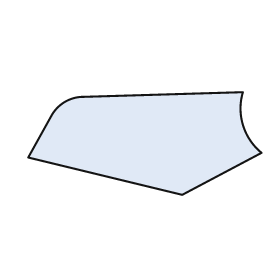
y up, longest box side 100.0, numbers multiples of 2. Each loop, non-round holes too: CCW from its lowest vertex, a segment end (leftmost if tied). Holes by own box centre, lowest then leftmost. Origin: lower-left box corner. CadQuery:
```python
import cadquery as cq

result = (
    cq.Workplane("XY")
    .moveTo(66.0, 0.0)
    .lineTo(100.0, 18.0)
    .threePointArc((92.0, 30.0), (92.0, 44.0))
    .lineTo(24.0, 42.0)
    .threePointArc((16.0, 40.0), (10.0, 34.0))
    .lineTo(0.0, 16.0)
    .close()
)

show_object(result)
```